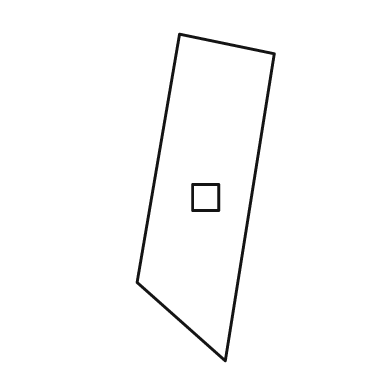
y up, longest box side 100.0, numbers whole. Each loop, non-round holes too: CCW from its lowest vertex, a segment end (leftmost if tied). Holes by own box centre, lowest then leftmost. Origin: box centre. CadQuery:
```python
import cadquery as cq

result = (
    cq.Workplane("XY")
    .moveTo(6.0, -50.0)
    .lineTo(21.0, 44.0)
    .lineTo(-8.0, 50.0)
    .lineTo(-21.0, -26.0)
    .close()
    .moveTo(-4.0, -4.0)
    .lineTo(4.0, -4.0)
    .lineTo(4.0, 4.0)
    .lineTo(-4.0, 4.0)
    .close()
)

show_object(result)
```